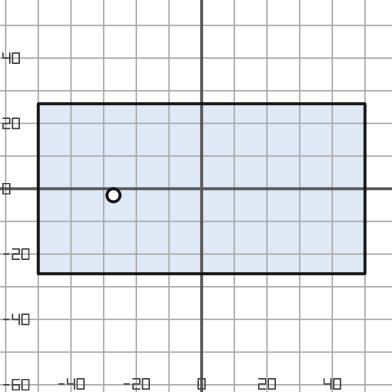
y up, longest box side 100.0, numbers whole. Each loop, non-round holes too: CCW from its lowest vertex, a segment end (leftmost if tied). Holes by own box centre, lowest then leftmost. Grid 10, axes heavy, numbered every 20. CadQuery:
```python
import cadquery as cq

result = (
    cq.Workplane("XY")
    .moveTo(-50.0, -26.0)
    .lineTo(50.0, -26.0)
    .lineTo(50.0, 26.0)
    .lineTo(-50.0, 26.0)
    .close()
    .moveTo(-27.0, -2.0)
    .circle(2.0)
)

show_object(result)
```